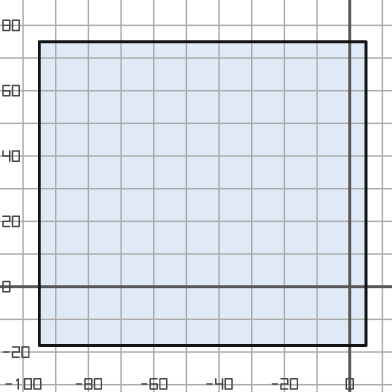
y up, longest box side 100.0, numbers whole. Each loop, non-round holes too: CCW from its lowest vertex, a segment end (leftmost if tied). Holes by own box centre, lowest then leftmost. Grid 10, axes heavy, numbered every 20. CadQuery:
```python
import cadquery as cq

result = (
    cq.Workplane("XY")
    .moveTo(-95.0, -18.0)
    .lineTo(5.0, -18.0)
    .lineTo(5.0, 75.0)
    .lineTo(-95.0, 75.0)
    .close()
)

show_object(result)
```